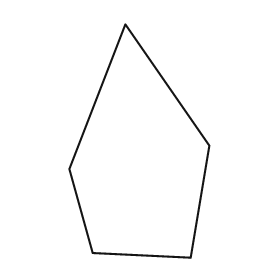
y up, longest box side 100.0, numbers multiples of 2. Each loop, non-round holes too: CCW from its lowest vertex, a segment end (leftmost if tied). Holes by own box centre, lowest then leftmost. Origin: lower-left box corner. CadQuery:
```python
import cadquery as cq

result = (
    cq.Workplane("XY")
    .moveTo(52.0, 0.0)
    .lineTo(60.0, 48.0)
    .lineTo(24.0, 100.0)
    .lineTo(0.0, 38.0)
    .lineTo(10.0, 2.0)
    .close()
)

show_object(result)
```